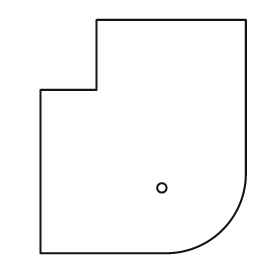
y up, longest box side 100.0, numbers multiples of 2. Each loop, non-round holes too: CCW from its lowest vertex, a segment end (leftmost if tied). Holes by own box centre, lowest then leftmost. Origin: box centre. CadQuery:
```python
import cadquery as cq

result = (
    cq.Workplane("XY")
    .moveTo(-44.0, -50.0)
    .lineTo(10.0, -50.0)
    .threePointArc((34.0, -40.0), (44.0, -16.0))
    .lineTo(44.0, 50.0)
    .lineTo(-20.0, 50.0)
    .lineTo(-20.0, 20.0)
    .lineTo(-44.0, 20.0)
    .close()
    .moveTo(8.0, -22.0)
    .circle(2.0)
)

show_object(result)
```